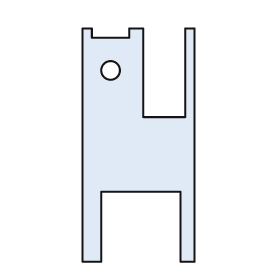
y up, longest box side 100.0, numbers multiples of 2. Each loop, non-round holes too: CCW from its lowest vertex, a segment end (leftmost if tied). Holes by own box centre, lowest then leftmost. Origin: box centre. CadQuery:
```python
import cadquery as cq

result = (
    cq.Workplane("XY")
    .moveTo(-24.0, -50.0)
    .lineTo(-16.0, -50.0)
    .lineTo(-16.0, -20.0)
    .lineTo(18.0, -20.0)
    .lineTo(18.0, -50.0)
    .lineTo(24.0, -50.0)
    .lineTo(24.0, 50.0)
    .lineTo(20.0, 50.0)
    .lineTo(20.0, 12.0)
    .lineTo(2.0, 12.0)
    .lineTo(2.0, 50.0)
    .lineTo(-4.0, 50.0)
    .lineTo(-4.0, 46.0)
    .lineTo(-20.0, 46.0)
    .lineTo(-20.0, 50.0)
    .lineTo(-24.0, 50.0)
    .close()
    .moveTo(-12.0, 32.0)
    .circle(4.0)
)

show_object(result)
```